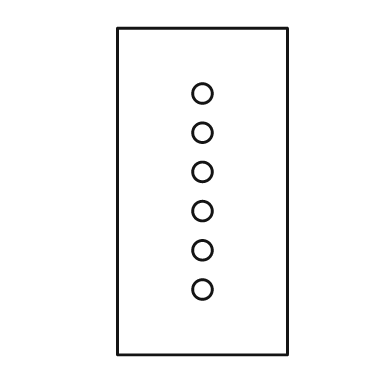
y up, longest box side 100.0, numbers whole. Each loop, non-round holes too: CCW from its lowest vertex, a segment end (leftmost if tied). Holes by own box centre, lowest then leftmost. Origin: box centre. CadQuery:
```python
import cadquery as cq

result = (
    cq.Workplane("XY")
    .moveTo(-26.0, -50.0)
    .lineTo(26.0, -50.0)
    .lineTo(26.0, 50.0)
    .lineTo(-26.0, 50.0)
    .close()
    .moveTo(0.0, -30.0)
    .circle(3.0)
    .moveTo(0.0, -18.0)
    .circle(3.0)
    .moveTo(0.0, -6.0)
    .circle(3.0)
    .moveTo(0.0, 6.0)
    .circle(3.0)
    .moveTo(0.0, 18.0)
    .circle(3.0)
    .moveTo(0.0, 30.0)
    .circle(3.0)
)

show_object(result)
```